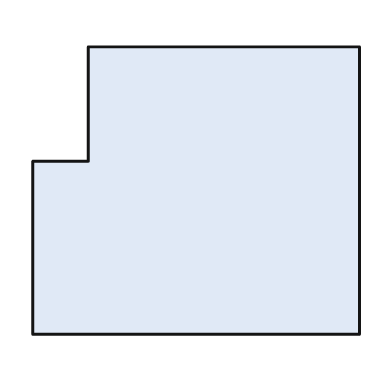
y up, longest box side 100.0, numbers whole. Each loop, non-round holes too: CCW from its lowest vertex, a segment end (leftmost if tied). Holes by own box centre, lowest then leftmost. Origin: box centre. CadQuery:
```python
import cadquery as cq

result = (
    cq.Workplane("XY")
    .moveTo(-50.0, -44.0)
    .lineTo(50.0, -44.0)
    .lineTo(50.0, 44.0)
    .lineTo(-33.0, 44.0)
    .lineTo(-33.0, 9.0)
    .lineTo(-50.0, 9.0)
    .close()
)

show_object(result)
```